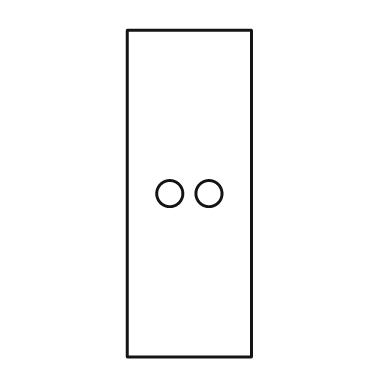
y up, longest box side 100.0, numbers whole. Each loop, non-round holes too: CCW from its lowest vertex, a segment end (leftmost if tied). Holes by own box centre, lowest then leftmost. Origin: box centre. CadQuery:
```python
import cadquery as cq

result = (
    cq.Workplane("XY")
    .moveTo(-19.0, -50.0)
    .lineTo(19.0, -50.0)
    .lineTo(19.0, 50.0)
    .lineTo(-19.0, 50.0)
    .close()
    .moveTo(-6.0, 0.0)
    .circle(4.0)
    .moveTo(6.0, 0.0)
    .circle(4.0)
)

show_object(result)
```